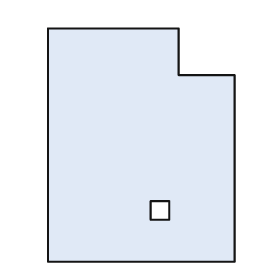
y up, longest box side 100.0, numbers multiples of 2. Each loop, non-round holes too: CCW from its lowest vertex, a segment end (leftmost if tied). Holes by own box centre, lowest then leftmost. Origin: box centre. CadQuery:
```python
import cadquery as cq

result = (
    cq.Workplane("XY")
    .moveTo(-40.0, -50.0)
    .lineTo(40.0, -50.0)
    .lineTo(40.0, 30.0)
    .lineTo(16.0, 30.0)
    .lineTo(16.0, 50.0)
    .lineTo(-40.0, 50.0)
    .close()
    .moveTo(4.0, -32.0)
    .lineTo(12.0, -32.0)
    .lineTo(12.0, -24.0)
    .lineTo(4.0, -24.0)
    .close()
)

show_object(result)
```